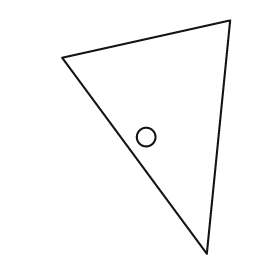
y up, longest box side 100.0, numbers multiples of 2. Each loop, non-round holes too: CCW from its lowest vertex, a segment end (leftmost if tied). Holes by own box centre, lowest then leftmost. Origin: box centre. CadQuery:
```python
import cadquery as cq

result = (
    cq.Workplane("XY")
    .moveTo(26.0, -50.0)
    .lineTo(36.0, 50.0)
    .lineTo(-36.0, 34.0)
    .close()
    .moveTo(0.0, 0.0)
    .circle(4.0)
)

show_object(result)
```